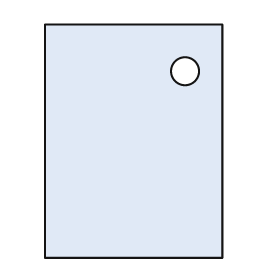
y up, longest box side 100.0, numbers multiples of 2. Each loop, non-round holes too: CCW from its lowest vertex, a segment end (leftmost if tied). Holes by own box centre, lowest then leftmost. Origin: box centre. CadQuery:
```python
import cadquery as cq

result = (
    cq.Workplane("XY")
    .moveTo(-38.0, -50.0)
    .lineTo(38.0, -50.0)
    .lineTo(38.0, 50.0)
    .lineTo(-38.0, 50.0)
    .close()
    .moveTo(22.0, 30.0)
    .circle(6.0)
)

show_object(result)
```